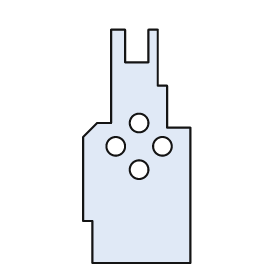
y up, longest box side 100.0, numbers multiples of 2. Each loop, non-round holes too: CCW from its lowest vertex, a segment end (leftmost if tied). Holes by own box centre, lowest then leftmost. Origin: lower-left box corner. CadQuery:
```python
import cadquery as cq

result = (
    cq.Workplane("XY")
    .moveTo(4.0, 0.0)
    .lineTo(46.0, 0.0)
    .lineTo(46.0, 58.0)
    .lineTo(36.0, 58.0)
    .lineTo(36.0, 76.0)
    .lineTo(32.0, 76.0)
    .lineTo(32.0, 100.0)
    .lineTo(28.0, 100.0)
    .lineTo(28.0, 86.0)
    .lineTo(18.0, 86.0)
    .lineTo(18.0, 100.0)
    .lineTo(12.0, 100.0)
    .lineTo(12.0, 60.0)
    .lineTo(6.0, 60.0)
    .lineTo(0.0, 54.0)
    .lineTo(0.0, 18.0)
    .lineTo(4.0, 18.0)
    .close()
    .moveTo(24.0, 40.0)
    .circle(4.0)
    .moveTo(14.0, 50.0)
    .circle(4.0)
    .moveTo(34.0, 50.0)
    .circle(4.0)
    .moveTo(24.0, 60.0)
    .circle(4.0)
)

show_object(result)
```